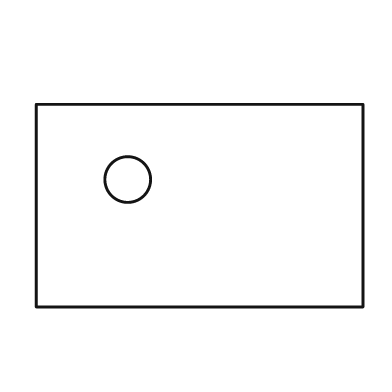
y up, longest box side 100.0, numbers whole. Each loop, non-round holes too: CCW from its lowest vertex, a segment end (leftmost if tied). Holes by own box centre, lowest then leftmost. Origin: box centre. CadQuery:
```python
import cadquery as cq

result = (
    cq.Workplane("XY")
    .moveTo(-50.0, -31.0)
    .lineTo(50.0, -31.0)
    .lineTo(50.0, 31.0)
    .lineTo(-50.0, 31.0)
    .close()
    .moveTo(-22.0, 8.0)
    .circle(7.0)
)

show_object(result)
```